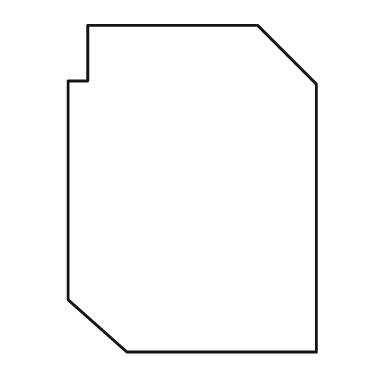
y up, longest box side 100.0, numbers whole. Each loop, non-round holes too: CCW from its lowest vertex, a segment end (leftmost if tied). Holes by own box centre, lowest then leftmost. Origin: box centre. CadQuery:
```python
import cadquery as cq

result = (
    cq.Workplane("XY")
    .moveTo(-20.0, -50.0)
    .lineTo(38.0, -50.0)
    .lineTo(38.0, 32.0)
    .lineTo(20.0, 50.0)
    .lineTo(-32.0, 50.0)
    .lineTo(-32.0, 33.0)
    .lineTo(-38.0, 33.0)
    .lineTo(-38.0, -34.0)
    .close()
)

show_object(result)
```